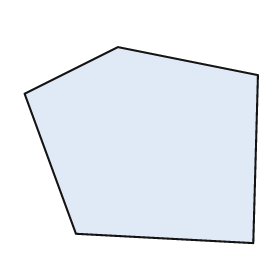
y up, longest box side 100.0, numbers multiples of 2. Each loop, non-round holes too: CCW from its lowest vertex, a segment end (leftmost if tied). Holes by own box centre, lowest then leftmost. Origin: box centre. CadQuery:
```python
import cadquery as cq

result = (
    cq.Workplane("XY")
    .moveTo(48.0, -42.0)
    .lineTo(50.0, 30.0)
    .lineTo(-10.0, 42.0)
    .lineTo(-50.0, 22.0)
    .lineTo(-28.0, -38.0)
    .close()
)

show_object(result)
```